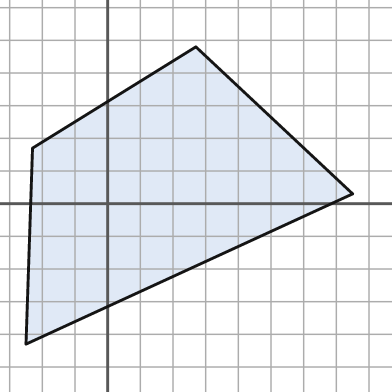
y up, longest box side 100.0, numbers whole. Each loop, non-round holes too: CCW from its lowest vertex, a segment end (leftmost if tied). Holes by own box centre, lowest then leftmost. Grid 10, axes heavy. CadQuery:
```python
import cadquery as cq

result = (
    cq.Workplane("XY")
    .moveTo(-25.0, -43.0)
    .lineTo(75.0, 3.0)
    .lineTo(27.0, 48.0)
    .lineTo(-23.0, 17.0)
    .close()
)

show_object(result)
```